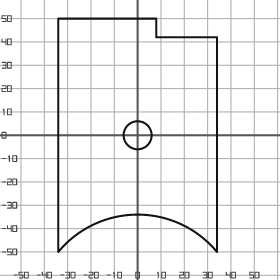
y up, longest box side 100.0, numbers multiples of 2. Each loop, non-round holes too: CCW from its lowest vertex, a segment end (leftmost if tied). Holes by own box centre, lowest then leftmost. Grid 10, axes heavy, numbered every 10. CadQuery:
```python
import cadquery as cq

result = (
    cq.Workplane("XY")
    .moveTo(-34.0, -50.0)
    .threePointArc((0.0, -34.0), (34.0, -50.0))
    .lineTo(34.0, 42.0)
    .lineTo(8.0, 42.0)
    .lineTo(8.0, 50.0)
    .lineTo(-34.0, 50.0)
    .close()
    .moveTo(0.0, 0.0)
    .circle(6.0)
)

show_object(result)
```